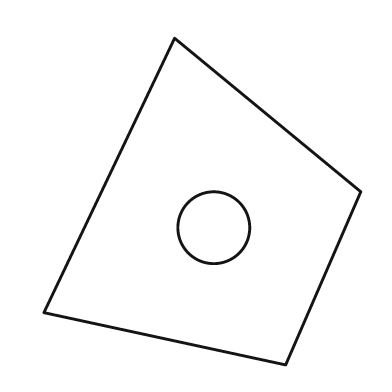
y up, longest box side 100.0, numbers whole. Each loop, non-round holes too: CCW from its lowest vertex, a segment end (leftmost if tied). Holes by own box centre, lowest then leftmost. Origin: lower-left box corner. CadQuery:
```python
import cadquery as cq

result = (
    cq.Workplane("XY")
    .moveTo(74.0, 0.0)
    .lineTo(97.0, 53.0)
    .lineTo(40.0, 100.0)
    .lineTo(0.0, 16.0)
    .close()
    .moveTo(52.0, 42.0)
    .circle(11.0)
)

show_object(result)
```